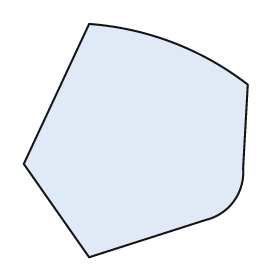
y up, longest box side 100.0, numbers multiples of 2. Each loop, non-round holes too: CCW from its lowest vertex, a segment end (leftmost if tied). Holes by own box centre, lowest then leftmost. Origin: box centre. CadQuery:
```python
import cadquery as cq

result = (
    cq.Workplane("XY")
    .moveTo(-20.0, -50.0)
    .lineTo(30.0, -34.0)
    .threePointArc((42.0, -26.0), (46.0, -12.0))
    .lineTo(48.0, 24.0)
    .threePointArc((16.0, 42.0), (-20.0, 50.0))
    .lineTo(-48.0, -10.0)
    .close()
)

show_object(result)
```